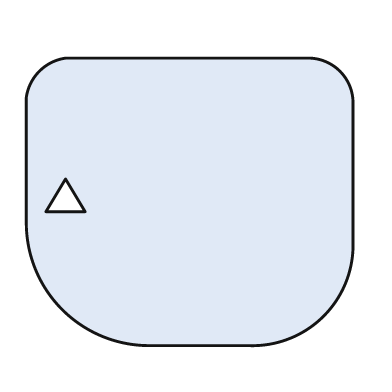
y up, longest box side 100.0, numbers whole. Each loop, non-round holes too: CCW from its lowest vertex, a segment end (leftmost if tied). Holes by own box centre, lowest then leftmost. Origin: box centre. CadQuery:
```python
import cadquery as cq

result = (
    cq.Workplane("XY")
    .moveTo(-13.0, -44.0)
    .lineTo(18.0, -44.0)
    .threePointArc((41.0, -35.0), (50.0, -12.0))
    .lineTo(50.0, 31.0)
    .threePointArc((46.0, 40.0), (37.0, 44.0))
    .lineTo(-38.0, 44.0)
    .threePointArc((-46.0, 40.0), (-50.0, 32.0))
    .lineTo(-50.0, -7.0)
    .threePointArc((-39.0, -33.0), (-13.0, -44.0))
    .close()
    .moveTo(-44.0, -3.0)
    .lineTo(-32.0, -3.0)
    .lineTo(-38.0, 7.0)
    .close()
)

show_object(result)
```